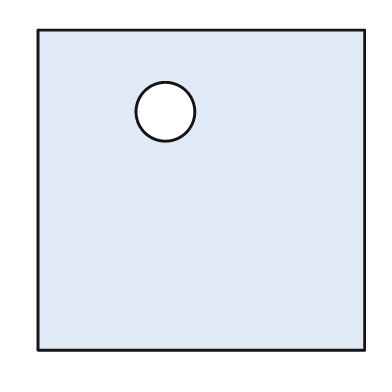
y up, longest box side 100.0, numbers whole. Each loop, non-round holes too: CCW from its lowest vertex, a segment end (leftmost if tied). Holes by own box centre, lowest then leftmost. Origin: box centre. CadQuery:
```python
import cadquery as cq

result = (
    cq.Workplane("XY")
    .moveTo(-50.0, -49.0)
    .lineTo(50.0, -49.0)
    .lineTo(50.0, 49.0)
    .lineTo(-50.0, 49.0)
    .close()
    .moveTo(-11.0, 24.0)
    .circle(9.0)
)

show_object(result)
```